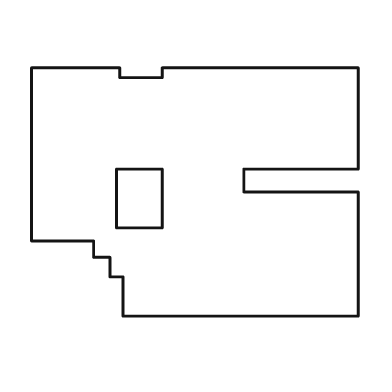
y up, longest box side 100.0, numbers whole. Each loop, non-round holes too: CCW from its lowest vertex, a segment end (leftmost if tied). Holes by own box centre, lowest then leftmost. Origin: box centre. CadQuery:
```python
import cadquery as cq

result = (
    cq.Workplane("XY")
    .moveTo(-22.0, -38.0)
    .lineTo(50.0, -38.0)
    .lineTo(50.0, 0.0)
    .lineTo(15.0, 0.0)
    .lineTo(15.0, 7.0)
    .lineTo(50.0, 7.0)
    .lineTo(50.0, 38.0)
    .lineTo(-10.0, 38.0)
    .lineTo(-10.0, 35.0)
    .lineTo(-23.0, 35.0)
    .lineTo(-23.0, 38.0)
    .lineTo(-50.0, 38.0)
    .lineTo(-50.0, -15.0)
    .lineTo(-31.0, -15.0)
    .lineTo(-31.0, -20.0)
    .lineTo(-26.0, -20.0)
    .lineTo(-26.0, -26.0)
    .lineTo(-22.0, -26.0)
    .close()
    .moveTo(-24.0, -11.0)
    .lineTo(-10.0, -11.0)
    .lineTo(-10.0, 7.0)
    .lineTo(-24.0, 7.0)
    .close()
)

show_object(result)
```